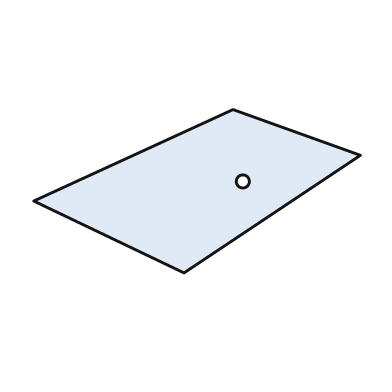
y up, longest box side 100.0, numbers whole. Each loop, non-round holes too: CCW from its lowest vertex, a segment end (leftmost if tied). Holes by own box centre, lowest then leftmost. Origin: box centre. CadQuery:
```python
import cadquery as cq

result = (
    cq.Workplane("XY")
    .moveTo(-4.0, -25.0)
    .lineTo(50.0, 11.0)
    .lineTo(11.0, 25.0)
    .lineTo(-50.0, -3.0)
    .close()
    .moveTo(14.0, 3.0)
    .circle(2.0)
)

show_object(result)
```